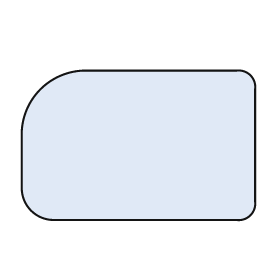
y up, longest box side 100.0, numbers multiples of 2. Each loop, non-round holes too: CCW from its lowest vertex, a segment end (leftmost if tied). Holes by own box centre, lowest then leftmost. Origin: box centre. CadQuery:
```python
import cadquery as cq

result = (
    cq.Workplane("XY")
    .moveTo(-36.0, -32.0)
    .lineTo(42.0, -32.0)
    .threePointArc((48.0, -30.0), (50.0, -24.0))
    .lineTo(50.0, 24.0)
    .threePointArc((48.0, 30.0), (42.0, 32.0))
    .lineTo(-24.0, 32.0)
    .threePointArc((-42.0, 24.0), (-50.0, 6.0))
    .lineTo(-50.0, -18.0)
    .threePointArc((-46.0, -28.0), (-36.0, -32.0))
    .close()
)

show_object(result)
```